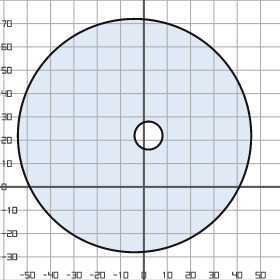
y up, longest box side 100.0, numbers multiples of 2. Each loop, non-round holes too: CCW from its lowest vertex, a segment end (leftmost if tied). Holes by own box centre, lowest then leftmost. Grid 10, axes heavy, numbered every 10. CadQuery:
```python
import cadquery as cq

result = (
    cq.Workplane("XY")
    .moveTo(-4.0, 22.0)
    .circle(50.0)
    .moveTo(2.0, 22.0)
    .circle(6.0)
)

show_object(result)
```